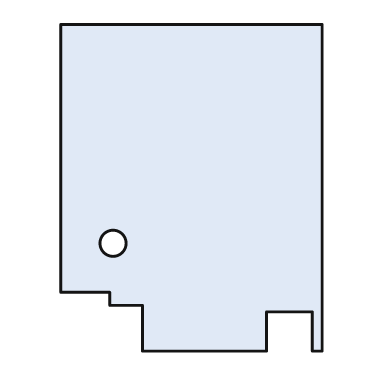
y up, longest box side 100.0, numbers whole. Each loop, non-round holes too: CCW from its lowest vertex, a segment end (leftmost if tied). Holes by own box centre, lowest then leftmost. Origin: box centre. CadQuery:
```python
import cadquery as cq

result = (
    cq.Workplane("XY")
    .moveTo(-15.0, -50.0)
    .lineTo(23.0, -50.0)
    .lineTo(23.0, -38.0)
    .lineTo(37.0, -38.0)
    .lineTo(37.0, -50.0)
    .lineTo(40.0, -50.0)
    .lineTo(40.0, 50.0)
    .lineTo(-40.0, 50.0)
    .lineTo(-40.0, -32.0)
    .lineTo(-25.0, -32.0)
    .lineTo(-25.0, -36.0)
    .lineTo(-15.0, -36.0)
    .close()
    .moveTo(-24.0, -17.0)
    .circle(4.0)
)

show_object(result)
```